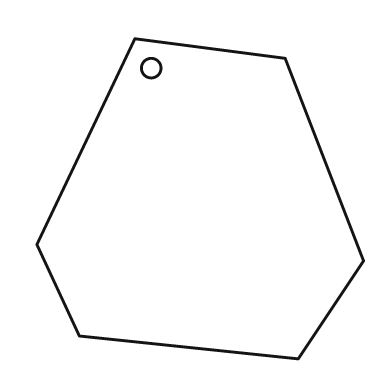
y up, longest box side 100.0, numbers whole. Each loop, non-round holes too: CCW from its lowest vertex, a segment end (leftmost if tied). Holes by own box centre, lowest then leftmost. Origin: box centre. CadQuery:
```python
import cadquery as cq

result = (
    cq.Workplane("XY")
    .moveTo(30.0, -49.0)
    .lineTo(50.0, -19.0)
    .lineTo(26.0, 43.0)
    .lineTo(-20.0, 49.0)
    .lineTo(-50.0, -14.0)
    .lineTo(-37.0, -42.0)
    .close()
    .moveTo(-15.0, 40.0)
    .circle(3.0)
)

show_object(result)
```